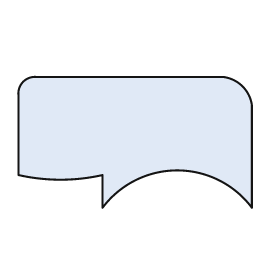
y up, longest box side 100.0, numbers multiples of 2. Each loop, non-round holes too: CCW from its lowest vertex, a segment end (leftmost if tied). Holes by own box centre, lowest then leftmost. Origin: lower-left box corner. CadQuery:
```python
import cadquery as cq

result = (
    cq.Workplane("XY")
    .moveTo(36.0, 0.0)
    .threePointArc((68.0, 16.0), (100.0, 0.0))
    .lineTo(100.0, 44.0)
    .threePointArc((96.0, 52.0), (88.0, 56.0))
    .lineTo(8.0, 56.0)
    .threePointArc((2.0, 54.0), (0.0, 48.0))
    .lineTo(0.0, 14.0)
    .threePointArc((18.0, 12.0), (36.0, 14.0))
    .close()
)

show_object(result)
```